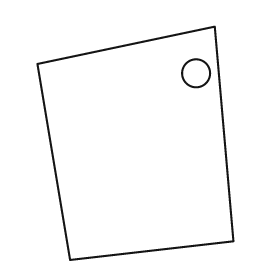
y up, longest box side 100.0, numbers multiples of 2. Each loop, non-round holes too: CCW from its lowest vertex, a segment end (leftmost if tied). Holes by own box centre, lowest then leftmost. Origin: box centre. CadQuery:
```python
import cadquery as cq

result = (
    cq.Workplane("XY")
    .moveTo(-28.0, -50.0)
    .lineTo(42.0, -42.0)
    .lineTo(34.0, 50.0)
    .lineTo(-42.0, 34.0)
    .close()
    .moveTo(26.0, 30.0)
    .circle(6.0)
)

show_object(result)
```